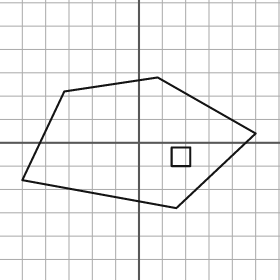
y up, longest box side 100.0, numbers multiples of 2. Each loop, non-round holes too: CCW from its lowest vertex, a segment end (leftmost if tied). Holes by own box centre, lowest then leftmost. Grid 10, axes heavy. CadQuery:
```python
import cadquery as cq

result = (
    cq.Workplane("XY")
    .moveTo(16.0, -28.0)
    .lineTo(50.0, 4.0)
    .lineTo(8.0, 28.0)
    .lineTo(-32.0, 22.0)
    .lineTo(-50.0, -16.0)
    .close()
    .moveTo(14.0, -10.0)
    .lineTo(22.0, -10.0)
    .lineTo(22.0, -2.0)
    .lineTo(14.0, -2.0)
    .close()
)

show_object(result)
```